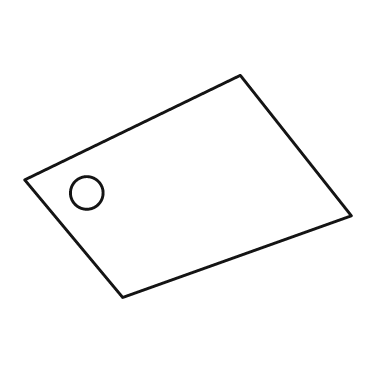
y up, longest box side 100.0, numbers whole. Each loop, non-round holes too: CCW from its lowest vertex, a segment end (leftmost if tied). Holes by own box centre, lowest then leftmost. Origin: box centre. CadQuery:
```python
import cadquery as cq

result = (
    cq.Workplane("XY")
    .moveTo(-20.0, -34.0)
    .lineTo(50.0, -9.0)
    .lineTo(16.0, 34.0)
    .lineTo(-50.0, 2.0)
    .close()
    .moveTo(-31.0, -2.0)
    .circle(5.0)
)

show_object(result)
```